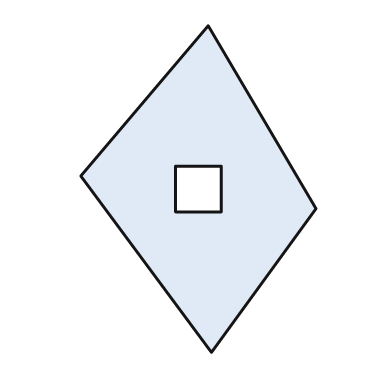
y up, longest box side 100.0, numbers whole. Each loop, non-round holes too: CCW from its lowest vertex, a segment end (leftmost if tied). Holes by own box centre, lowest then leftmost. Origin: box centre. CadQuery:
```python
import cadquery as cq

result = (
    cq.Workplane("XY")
    .moveTo(4.0, -50.0)
    .lineTo(36.0, -6.0)
    .lineTo(3.0, 50.0)
    .lineTo(-36.0, 4.0)
    .close()
    .moveTo(-7.0, -7.0)
    .lineTo(7.0, -7.0)
    .lineTo(7.0, 7.0)
    .lineTo(-7.0, 7.0)
    .close()
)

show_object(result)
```